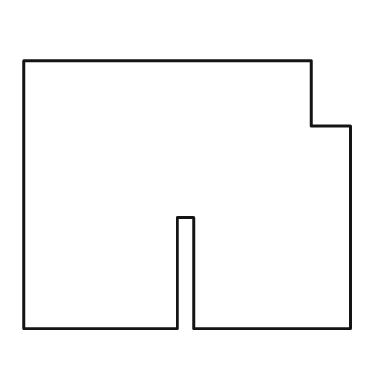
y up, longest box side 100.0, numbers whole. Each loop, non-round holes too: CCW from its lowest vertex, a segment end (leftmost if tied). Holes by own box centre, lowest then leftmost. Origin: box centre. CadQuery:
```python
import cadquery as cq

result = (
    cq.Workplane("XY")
    .moveTo(-50.0, -41.0)
    .lineTo(-3.0, -41.0)
    .lineTo(-3.0, -7.0)
    .lineTo(2.0, -7.0)
    .lineTo(2.0, -41.0)
    .lineTo(50.0, -41.0)
    .lineTo(50.0, 21.0)
    .lineTo(38.0, 21.0)
    .lineTo(38.0, 41.0)
    .lineTo(-50.0, 41.0)
    .close()
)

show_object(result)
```